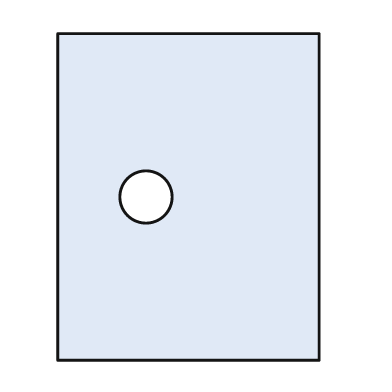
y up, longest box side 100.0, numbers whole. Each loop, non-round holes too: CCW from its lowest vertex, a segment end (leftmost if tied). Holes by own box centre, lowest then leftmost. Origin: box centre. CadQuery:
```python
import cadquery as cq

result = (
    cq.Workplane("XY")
    .moveTo(-40.0, -50.0)
    .lineTo(40.0, -50.0)
    .lineTo(40.0, 50.0)
    .lineTo(-40.0, 50.0)
    .close()
    .moveTo(-13.0, 0.0)
    .circle(8.0)
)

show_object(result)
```